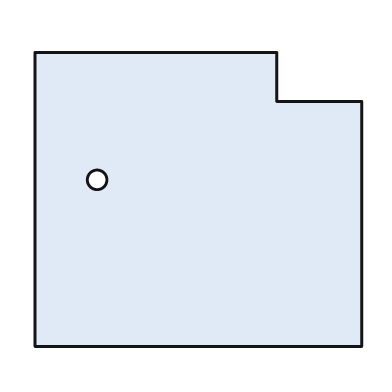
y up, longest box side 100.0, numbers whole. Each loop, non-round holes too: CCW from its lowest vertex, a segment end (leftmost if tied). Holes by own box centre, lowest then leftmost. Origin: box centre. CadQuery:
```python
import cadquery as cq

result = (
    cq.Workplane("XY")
    .moveTo(-50.0, -45.0)
    .lineTo(50.0, -45.0)
    .lineTo(50.0, 30.0)
    .lineTo(24.0, 30.0)
    .lineTo(24.0, 45.0)
    .lineTo(-50.0, 45.0)
    .close()
    .moveTo(-31.0, 6.0)
    .circle(3.0)
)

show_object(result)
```